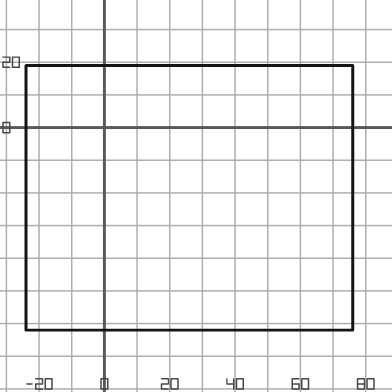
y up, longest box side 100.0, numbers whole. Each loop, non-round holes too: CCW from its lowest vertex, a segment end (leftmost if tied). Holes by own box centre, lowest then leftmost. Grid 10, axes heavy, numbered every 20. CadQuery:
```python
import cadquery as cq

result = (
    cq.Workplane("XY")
    .moveTo(-24.0, -62.0)
    .lineTo(76.0, -62.0)
    .lineTo(76.0, 19.0)
    .lineTo(-24.0, 19.0)
    .close()
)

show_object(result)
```